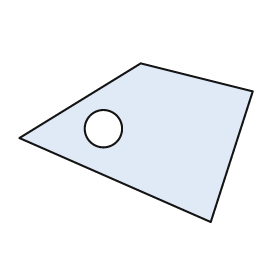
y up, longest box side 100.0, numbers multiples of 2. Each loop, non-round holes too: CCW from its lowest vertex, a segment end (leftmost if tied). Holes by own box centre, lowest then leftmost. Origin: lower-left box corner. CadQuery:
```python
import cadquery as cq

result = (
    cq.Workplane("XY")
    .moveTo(82.0, 0.0)
    .lineTo(100.0, 56.0)
    .lineTo(52.0, 68.0)
    .lineTo(0.0, 36.0)
    .close()
    .moveTo(36.0, 40.0)
    .circle(8.0)
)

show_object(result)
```